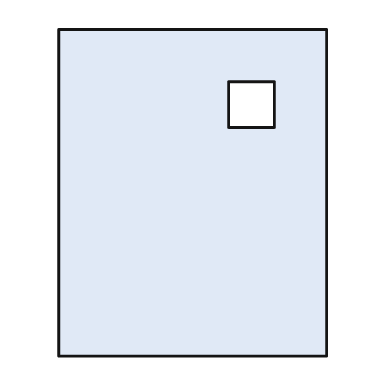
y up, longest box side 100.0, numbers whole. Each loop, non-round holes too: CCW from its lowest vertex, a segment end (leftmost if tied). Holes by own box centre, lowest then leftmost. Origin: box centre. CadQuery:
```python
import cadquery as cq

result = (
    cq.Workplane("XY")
    .moveTo(-41.0, -50.0)
    .lineTo(41.0, -50.0)
    .lineTo(41.0, 50.0)
    .lineTo(-41.0, 50.0)
    .close()
    .moveTo(11.0, 20.0)
    .lineTo(25.0, 20.0)
    .lineTo(25.0, 34.0)
    .lineTo(11.0, 34.0)
    .close()
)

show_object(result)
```